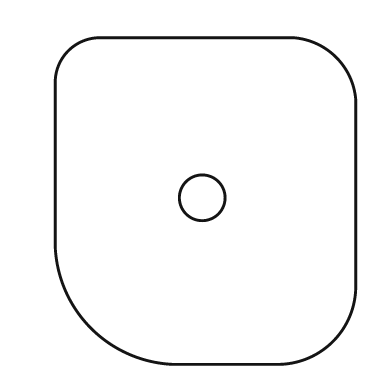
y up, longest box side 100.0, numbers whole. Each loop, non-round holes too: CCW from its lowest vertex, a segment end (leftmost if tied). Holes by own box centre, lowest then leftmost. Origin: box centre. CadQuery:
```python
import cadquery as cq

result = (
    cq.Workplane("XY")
    .moveTo(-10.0, -50.0)
    .lineTo(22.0, -50.0)
    .threePointArc((39.0, -43.0), (46.0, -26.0))
    .lineTo(46.0, 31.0)
    .threePointArc((40.0, 44.0), (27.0, 50.0))
    .lineTo(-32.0, 50.0)
    .threePointArc((-42.0, 46.0), (-46.0, 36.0))
    .lineTo(-46.0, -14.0)
    .threePointArc((-35.0, -39.0), (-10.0, -50.0))
    .close()
    .moveTo(-1.0, 1.0)
    .circle(7.0)
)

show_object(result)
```